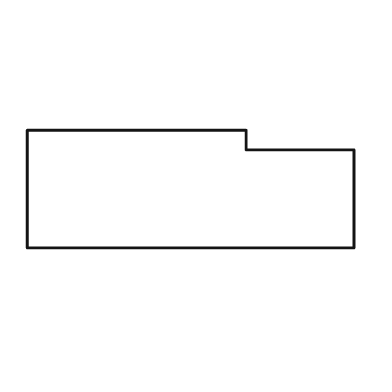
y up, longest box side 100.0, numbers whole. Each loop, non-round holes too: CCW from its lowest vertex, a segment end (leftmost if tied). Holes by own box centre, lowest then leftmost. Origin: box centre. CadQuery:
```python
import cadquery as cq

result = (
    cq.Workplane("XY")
    .moveTo(-50.0, -18.0)
    .lineTo(50.0, -18.0)
    .lineTo(50.0, 12.0)
    .lineTo(17.0, 12.0)
    .lineTo(17.0, 18.0)
    .lineTo(-50.0, 18.0)
    .close()
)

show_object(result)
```